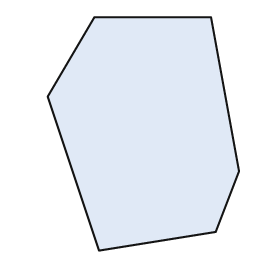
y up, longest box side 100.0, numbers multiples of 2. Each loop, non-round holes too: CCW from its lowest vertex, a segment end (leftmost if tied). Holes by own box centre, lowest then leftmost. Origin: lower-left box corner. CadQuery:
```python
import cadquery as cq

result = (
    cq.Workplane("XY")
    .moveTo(22.0, 0.0)
    .lineTo(72.0, 8.0)
    .lineTo(82.0, 34.0)
    .lineTo(70.0, 100.0)
    .lineTo(20.0, 100.0)
    .lineTo(0.0, 66.0)
    .close()
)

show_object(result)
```